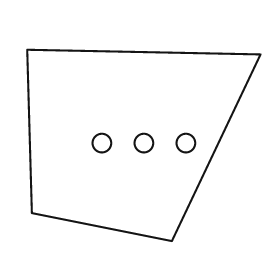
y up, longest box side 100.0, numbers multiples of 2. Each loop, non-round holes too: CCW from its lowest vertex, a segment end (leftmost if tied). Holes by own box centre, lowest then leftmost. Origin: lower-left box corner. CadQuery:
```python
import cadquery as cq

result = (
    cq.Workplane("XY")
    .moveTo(62.0, 0.0)
    .lineTo(100.0, 80.0)
    .lineTo(0.0, 82.0)
    .lineTo(2.0, 12.0)
    .close()
    .moveTo(32.0, 42.0)
    .circle(4.0)
    .moveTo(50.0, 42.0)
    .circle(4.0)
    .moveTo(68.0, 42.0)
    .circle(4.0)
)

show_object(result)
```